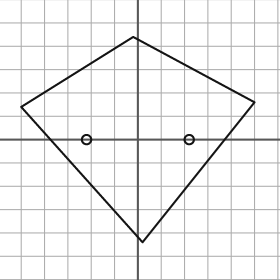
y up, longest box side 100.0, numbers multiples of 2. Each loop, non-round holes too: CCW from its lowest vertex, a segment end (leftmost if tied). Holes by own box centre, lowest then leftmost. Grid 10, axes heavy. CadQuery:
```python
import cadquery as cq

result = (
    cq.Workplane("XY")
    .moveTo(2.0, -44.0)
    .lineTo(50.0, 16.0)
    .lineTo(-2.0, 44.0)
    .lineTo(-50.0, 14.0)
    .close()
    .moveTo(-22.0, 0.0)
    .circle(2.0)
    .moveTo(22.0, 0.0)
    .circle(2.0)
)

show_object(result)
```